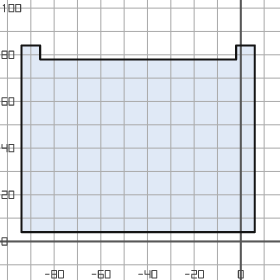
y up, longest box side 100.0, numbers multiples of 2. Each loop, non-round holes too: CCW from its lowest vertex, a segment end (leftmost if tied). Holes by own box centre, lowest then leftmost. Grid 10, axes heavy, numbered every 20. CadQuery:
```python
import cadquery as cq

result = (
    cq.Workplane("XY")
    .moveTo(-94.0, 4.0)
    .lineTo(6.0, 4.0)
    .lineTo(6.0, 84.0)
    .lineTo(-2.0, 84.0)
    .lineTo(-2.0, 78.0)
    .lineTo(-86.0, 78.0)
    .lineTo(-86.0, 84.0)
    .lineTo(-94.0, 84.0)
    .close()
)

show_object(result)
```